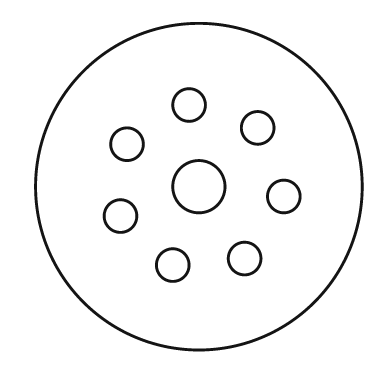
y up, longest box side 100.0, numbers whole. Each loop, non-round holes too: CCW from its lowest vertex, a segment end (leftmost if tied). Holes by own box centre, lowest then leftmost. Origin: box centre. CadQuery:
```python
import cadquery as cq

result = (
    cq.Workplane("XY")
    .moveTo(0.0, 0.0)
    .circle(50.0)
    .moveTo(-8.0, -24.0)
    .circle(5.0)
    .moveTo(14.0, -22.0)
    .circle(5.0)
    .moveTo(-24.0, -9.0)
    .circle(5.0)
    .moveTo(26.0, -3.0)
    .circle(5.0)
    .moveTo(0.0, 0.0)
    .circle(8.0)
    .moveTo(-22.0, 13.0)
    .circle(5.0)
    .moveTo(18.0, 18.0)
    .circle(5.0)
    .moveTo(-3.0, 25.0)
    .circle(5.0)
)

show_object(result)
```